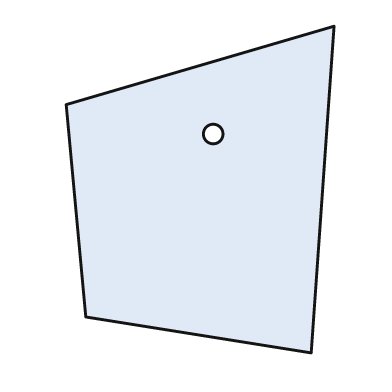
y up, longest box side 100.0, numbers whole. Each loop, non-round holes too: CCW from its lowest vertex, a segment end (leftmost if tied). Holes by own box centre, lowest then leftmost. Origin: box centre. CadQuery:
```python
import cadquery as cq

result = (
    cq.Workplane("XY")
    .moveTo(34.0, -50.0)
    .lineTo(41.0, 50.0)
    .lineTo(-41.0, 26.0)
    .lineTo(-35.0, -39.0)
    .close()
    .moveTo(4.0, 17.0)
    .circle(3.0)
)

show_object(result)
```